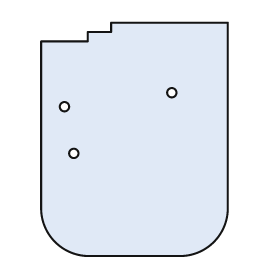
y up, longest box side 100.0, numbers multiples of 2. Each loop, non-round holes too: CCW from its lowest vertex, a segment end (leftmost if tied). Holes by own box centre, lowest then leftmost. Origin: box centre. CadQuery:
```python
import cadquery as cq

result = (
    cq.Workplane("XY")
    .moveTo(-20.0, -50.0)
    .lineTo(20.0, -50.0)
    .threePointArc((34.0, -44.0), (40.0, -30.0))
    .lineTo(40.0, 50.0)
    .lineTo(-10.0, 50.0)
    .lineTo(-10.0, 46.0)
    .lineTo(-20.0, 46.0)
    .lineTo(-20.0, 42.0)
    .lineTo(-40.0, 42.0)
    .lineTo(-40.0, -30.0)
    .threePointArc((-34.0, -44.0), (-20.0, -50.0))
    .close()
    .moveTo(-26.0, -6.0)
    .circle(2.0)
    .moveTo(-30.0, 14.0)
    .circle(2.0)
    .moveTo(16.0, 20.0)
    .circle(2.0)
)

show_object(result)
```